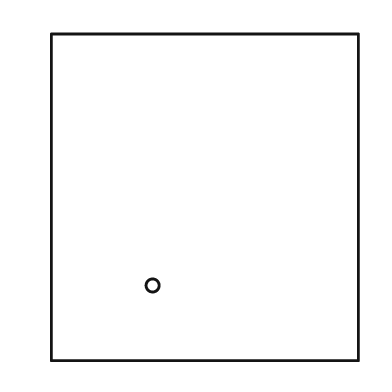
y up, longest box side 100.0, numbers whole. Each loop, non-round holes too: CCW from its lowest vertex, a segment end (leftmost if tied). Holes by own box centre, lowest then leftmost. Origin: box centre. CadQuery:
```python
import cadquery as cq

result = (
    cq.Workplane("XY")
    .moveTo(-47.0, -50.0)
    .lineTo(47.0, -50.0)
    .lineTo(47.0, 50.0)
    .lineTo(-47.0, 50.0)
    .close()
    .moveTo(-16.0, -27.0)
    .circle(2.0)
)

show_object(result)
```